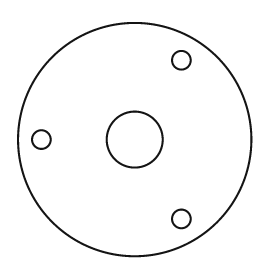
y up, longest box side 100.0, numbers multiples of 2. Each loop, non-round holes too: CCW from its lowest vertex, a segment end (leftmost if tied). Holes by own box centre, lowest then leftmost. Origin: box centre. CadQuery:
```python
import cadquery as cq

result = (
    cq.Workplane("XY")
    .moveTo(0.0, 0.0)
    .circle(50.0)
    .moveTo(20.0, -34.0)
    .circle(4.0)
    .moveTo(-40.0, 0.0)
    .circle(4.0)
    .moveTo(0.0, 0.0)
    .circle(12.0)
    .moveTo(20.0, 34.0)
    .circle(4.0)
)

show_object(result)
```